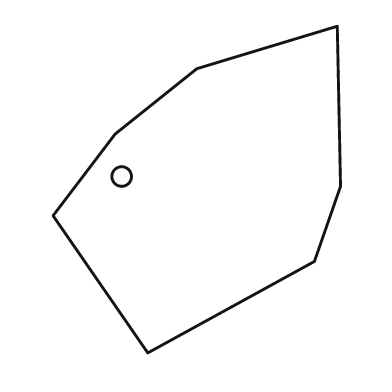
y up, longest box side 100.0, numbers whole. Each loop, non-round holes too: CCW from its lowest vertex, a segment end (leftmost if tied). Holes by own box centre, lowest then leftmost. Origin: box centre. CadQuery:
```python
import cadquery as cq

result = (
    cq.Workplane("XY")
    .moveTo(-15.0, -50.0)
    .lineTo(36.0, -22.0)
    .lineTo(44.0, 1.0)
    .lineTo(43.0, 50.0)
    .lineTo(0.0, 37.0)
    .lineTo(-25.0, 17.0)
    .lineTo(-44.0, -8.0)
    .close()
    .moveTo(-23.0, 4.0)
    .circle(3.0)
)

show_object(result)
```